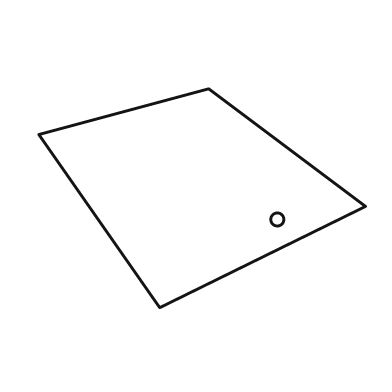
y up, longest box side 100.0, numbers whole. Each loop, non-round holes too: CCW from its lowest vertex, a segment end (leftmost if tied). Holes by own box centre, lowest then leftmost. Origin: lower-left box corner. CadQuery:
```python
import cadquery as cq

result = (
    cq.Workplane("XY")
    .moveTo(37.0, 0.0)
    .lineTo(100.0, 31.0)
    .lineTo(52.0, 67.0)
    .lineTo(0.0, 53.0)
    .close()
    .moveTo(73.0, 27.0)
    .circle(2.0)
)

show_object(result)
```